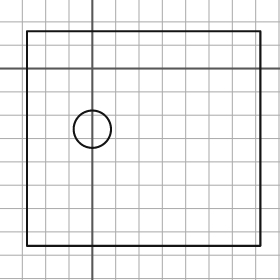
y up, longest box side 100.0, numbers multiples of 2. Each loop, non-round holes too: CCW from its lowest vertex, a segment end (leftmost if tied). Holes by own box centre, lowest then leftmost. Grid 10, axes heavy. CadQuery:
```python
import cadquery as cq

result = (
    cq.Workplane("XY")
    .moveTo(-28.0, -76.0)
    .lineTo(72.0, -76.0)
    .lineTo(72.0, 16.0)
    .lineTo(-28.0, 16.0)
    .close()
    .moveTo(0.0, -26.0)
    .circle(8.0)
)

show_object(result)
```